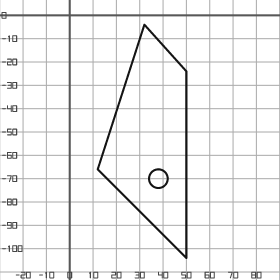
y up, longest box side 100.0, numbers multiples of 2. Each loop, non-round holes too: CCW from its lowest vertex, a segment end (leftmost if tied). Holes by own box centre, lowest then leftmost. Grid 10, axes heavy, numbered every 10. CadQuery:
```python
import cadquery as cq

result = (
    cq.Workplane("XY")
    .moveTo(50.0, -104.0)
    .lineTo(50.0, -24.0)
    .lineTo(32.0, -4.0)
    .lineTo(12.0, -66.0)
    .close()
    .moveTo(38.0, -70.0)
    .circle(4.0)
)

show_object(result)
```